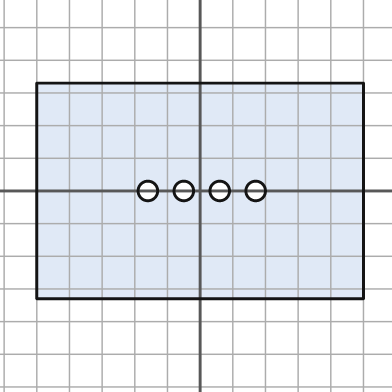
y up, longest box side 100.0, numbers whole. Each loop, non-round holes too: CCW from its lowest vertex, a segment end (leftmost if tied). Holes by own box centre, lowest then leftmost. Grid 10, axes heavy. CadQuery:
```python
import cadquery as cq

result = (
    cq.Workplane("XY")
    .moveTo(-50.0, -33.0)
    .lineTo(50.0, -33.0)
    .lineTo(50.0, 33.0)
    .lineTo(-50.0, 33.0)
    .close()
    .moveTo(-16.0, 0.0)
    .circle(3.0)
    .moveTo(-5.0, 0.0)
    .circle(3.0)
    .moveTo(6.0, 0.0)
    .circle(3.0)
    .moveTo(17.0, 0.0)
    .circle(3.0)
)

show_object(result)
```